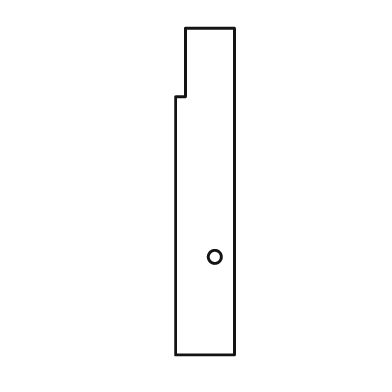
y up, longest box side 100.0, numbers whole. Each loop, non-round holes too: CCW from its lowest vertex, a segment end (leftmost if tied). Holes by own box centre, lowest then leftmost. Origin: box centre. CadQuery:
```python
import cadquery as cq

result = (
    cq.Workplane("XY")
    .moveTo(-9.0, -50.0)
    .lineTo(9.0, -50.0)
    .lineTo(9.0, 50.0)
    .lineTo(-6.0, 50.0)
    .lineTo(-6.0, 29.0)
    .lineTo(-9.0, 29.0)
    .close()
    .moveTo(3.0, -20.0)
    .circle(2.0)
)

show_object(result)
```